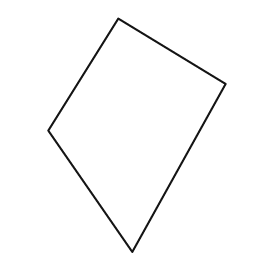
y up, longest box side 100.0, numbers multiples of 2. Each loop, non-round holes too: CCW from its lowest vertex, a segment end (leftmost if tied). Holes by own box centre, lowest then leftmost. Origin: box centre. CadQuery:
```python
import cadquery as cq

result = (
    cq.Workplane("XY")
    .moveTo(-2.0, -50.0)
    .lineTo(38.0, 22.0)
    .lineTo(-8.0, 50.0)
    .lineTo(-38.0, 2.0)
    .close()
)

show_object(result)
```